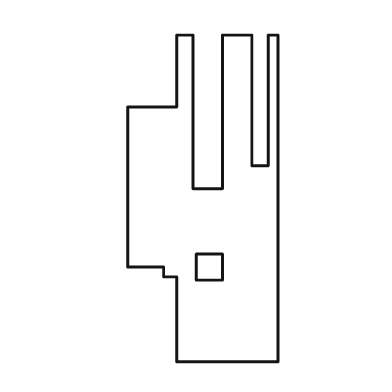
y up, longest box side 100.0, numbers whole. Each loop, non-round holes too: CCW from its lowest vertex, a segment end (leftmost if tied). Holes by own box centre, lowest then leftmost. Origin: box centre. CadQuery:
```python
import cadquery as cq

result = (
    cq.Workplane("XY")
    .moveTo(-8.0, -50.0)
    .lineTo(23.0, -50.0)
    .lineTo(23.0, 50.0)
    .lineTo(20.0, 50.0)
    .lineTo(20.0, 10.0)
    .lineTo(15.0, 10.0)
    .lineTo(15.0, 50.0)
    .lineTo(6.0, 50.0)
    .lineTo(6.0, 3.0)
    .lineTo(-3.0, 3.0)
    .lineTo(-3.0, 50.0)
    .lineTo(-8.0, 50.0)
    .lineTo(-8.0, 28.0)
    .lineTo(-23.0, 28.0)
    .lineTo(-23.0, -21.0)
    .lineTo(-12.0, -21.0)
    .lineTo(-12.0, -24.0)
    .lineTo(-8.0, -24.0)
    .close()
    .moveTo(-2.0, -25.0)
    .lineTo(6.0, -25.0)
    .lineTo(6.0, -17.0)
    .lineTo(-2.0, -17.0)
    .close()
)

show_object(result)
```